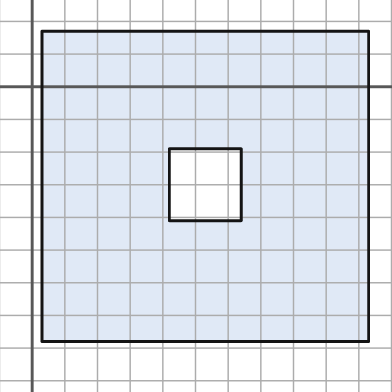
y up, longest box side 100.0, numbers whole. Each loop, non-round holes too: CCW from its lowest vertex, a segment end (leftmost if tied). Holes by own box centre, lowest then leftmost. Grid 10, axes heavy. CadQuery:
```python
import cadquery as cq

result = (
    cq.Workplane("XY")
    .moveTo(3.0, -78.0)
    .lineTo(103.0, -78.0)
    .lineTo(103.0, 17.0)
    .lineTo(3.0, 17.0)
    .close()
    .moveTo(42.0, -41.0)
    .lineTo(64.0, -41.0)
    .lineTo(64.0, -19.0)
    .lineTo(42.0, -19.0)
    .close()
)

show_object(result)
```